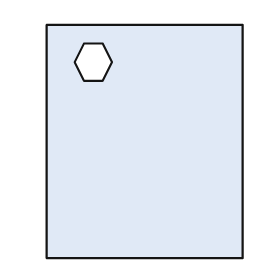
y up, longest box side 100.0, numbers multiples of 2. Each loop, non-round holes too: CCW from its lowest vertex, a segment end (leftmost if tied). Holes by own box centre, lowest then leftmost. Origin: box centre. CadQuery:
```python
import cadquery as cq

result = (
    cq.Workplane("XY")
    .moveTo(-42.0, -50.0)
    .lineTo(42.0, -50.0)
    .lineTo(42.0, 50.0)
    .lineTo(-42.0, 50.0)
    .close()
    .moveTo(-26.0, 26.0)
    .lineTo(-18.0, 26.0)
    .lineTo(-14.0, 34.0)
    .lineTo(-18.0, 42.0)
    .lineTo(-26.0, 42.0)
    .lineTo(-30.0, 34.0)
    .close()
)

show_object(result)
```